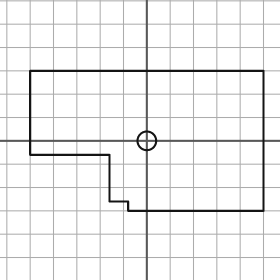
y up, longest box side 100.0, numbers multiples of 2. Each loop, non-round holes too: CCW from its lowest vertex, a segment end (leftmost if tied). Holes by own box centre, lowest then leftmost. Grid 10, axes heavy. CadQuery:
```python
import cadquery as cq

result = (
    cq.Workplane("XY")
    .moveTo(-8.0, -30.0)
    .lineTo(50.0, -30.0)
    .lineTo(50.0, 30.0)
    .lineTo(-50.0, 30.0)
    .lineTo(-50.0, -6.0)
    .lineTo(-16.0, -6.0)
    .lineTo(-16.0, -26.0)
    .lineTo(-8.0, -26.0)
    .close()
    .moveTo(0.0, 0.0)
    .circle(4.0)
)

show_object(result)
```